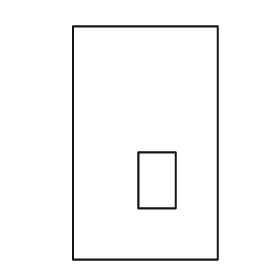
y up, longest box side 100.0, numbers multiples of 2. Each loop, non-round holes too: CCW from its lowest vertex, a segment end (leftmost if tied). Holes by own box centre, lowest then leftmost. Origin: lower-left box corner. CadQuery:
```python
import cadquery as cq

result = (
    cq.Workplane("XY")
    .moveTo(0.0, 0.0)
    .lineTo(62.0, 0.0)
    .lineTo(62.0, 100.0)
    .lineTo(0.0, 100.0)
    .close()
    .moveTo(28.0, 22.0)
    .lineTo(44.0, 22.0)
    .lineTo(44.0, 46.0)
    .lineTo(28.0, 46.0)
    .close()
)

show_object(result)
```